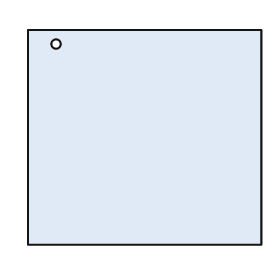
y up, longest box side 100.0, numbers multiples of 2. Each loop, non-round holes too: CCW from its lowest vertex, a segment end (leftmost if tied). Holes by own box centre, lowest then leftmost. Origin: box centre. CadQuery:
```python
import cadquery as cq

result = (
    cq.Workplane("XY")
    .moveTo(-50.0, -46.0)
    .lineTo(50.0, -46.0)
    .lineTo(50.0, 46.0)
    .lineTo(-50.0, 46.0)
    .close()
    .moveTo(-38.0, 40.0)
    .circle(2.0)
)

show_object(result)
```